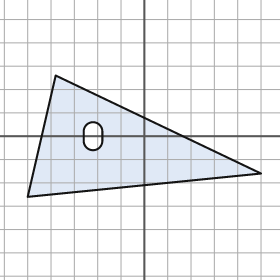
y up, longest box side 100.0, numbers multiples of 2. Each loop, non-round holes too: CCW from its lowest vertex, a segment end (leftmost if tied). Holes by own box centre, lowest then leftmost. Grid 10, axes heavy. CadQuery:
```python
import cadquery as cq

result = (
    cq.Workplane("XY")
    .moveTo(-50.0, -26.0)
    .lineTo(50.0, -16.0)
    .lineTo(-38.0, 26.0)
    .close()
    .moveTo(-26.0, -2.0)
    .threePointArc((-22.0, -6.0), (-18.0, -2.0))
    .lineTo(-18.0, 2.0)
    .threePointArc((-22.0, 6.0), (-26.0, 2.0))
    .close()
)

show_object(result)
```